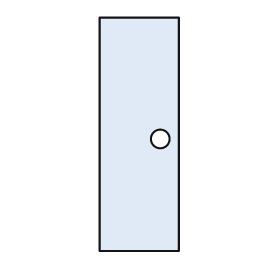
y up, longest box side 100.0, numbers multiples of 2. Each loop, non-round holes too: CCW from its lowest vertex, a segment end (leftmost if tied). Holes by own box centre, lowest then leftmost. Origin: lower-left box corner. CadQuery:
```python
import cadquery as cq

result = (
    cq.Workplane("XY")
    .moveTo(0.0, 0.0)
    .lineTo(34.0, 0.0)
    .lineTo(34.0, 100.0)
    .lineTo(0.0, 100.0)
    .close()
    .moveTo(26.0, 48.0)
    .circle(4.0)
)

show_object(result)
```